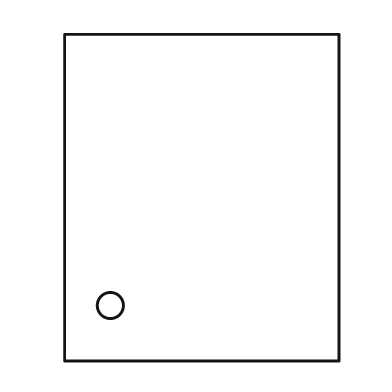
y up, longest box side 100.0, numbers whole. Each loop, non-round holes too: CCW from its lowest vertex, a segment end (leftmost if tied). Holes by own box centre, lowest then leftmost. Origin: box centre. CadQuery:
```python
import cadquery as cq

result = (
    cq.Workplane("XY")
    .moveTo(-42.0, -50.0)
    .lineTo(42.0, -50.0)
    .lineTo(42.0, 50.0)
    .lineTo(-42.0, 50.0)
    .close()
    .moveTo(-28.0, -33.0)
    .circle(4.0)
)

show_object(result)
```